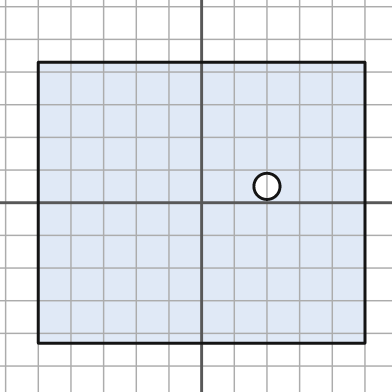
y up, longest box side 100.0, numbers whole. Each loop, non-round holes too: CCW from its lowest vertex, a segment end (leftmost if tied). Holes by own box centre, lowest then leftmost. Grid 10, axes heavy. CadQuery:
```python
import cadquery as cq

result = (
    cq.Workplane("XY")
    .moveTo(-50.0, -43.0)
    .lineTo(50.0, -43.0)
    .lineTo(50.0, 43.0)
    .lineTo(-50.0, 43.0)
    .close()
    .moveTo(20.0, 5.0)
    .circle(4.0)
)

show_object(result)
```